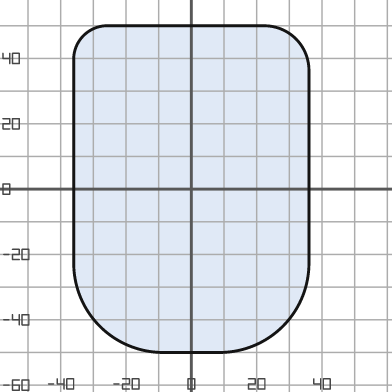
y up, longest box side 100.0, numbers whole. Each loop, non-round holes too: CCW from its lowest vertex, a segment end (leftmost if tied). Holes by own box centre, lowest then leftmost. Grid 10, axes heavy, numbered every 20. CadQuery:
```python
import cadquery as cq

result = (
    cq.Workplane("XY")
    .moveTo(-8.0, -50.0)
    .lineTo(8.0, -50.0)
    .threePointArc((28.0, -42.0), (36.0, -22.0))
    .lineTo(36.0, 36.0)
    .threePointArc((32.0, 46.0), (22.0, 50.0))
    .lineTo(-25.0, 50.0)
    .threePointArc((-33.0, 47.0), (-36.0, 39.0))
    .lineTo(-36.0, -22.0)
    .threePointArc((-28.0, -42.0), (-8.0, -50.0))
    .close()
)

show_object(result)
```